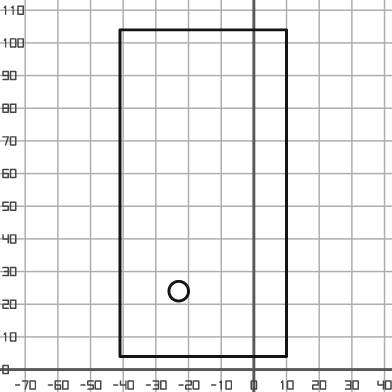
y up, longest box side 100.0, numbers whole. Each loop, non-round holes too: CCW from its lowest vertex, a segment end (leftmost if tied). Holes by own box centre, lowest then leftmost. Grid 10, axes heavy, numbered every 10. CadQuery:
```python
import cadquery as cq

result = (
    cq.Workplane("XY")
    .moveTo(-41.0, 4.0)
    .lineTo(10.0, 4.0)
    .lineTo(10.0, 104.0)
    .lineTo(-41.0, 104.0)
    .close()
    .moveTo(-23.0, 24.0)
    .circle(3.0)
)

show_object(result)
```